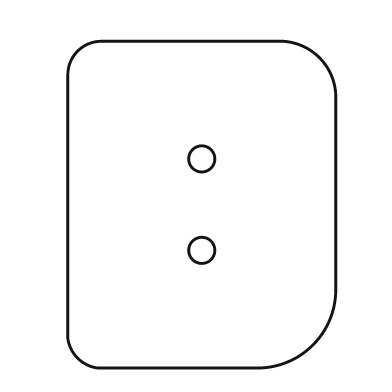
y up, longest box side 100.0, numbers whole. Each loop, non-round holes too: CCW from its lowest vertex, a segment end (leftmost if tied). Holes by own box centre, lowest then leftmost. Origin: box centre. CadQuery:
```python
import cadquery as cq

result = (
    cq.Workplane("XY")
    .moveTo(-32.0, -50.0)
    .lineTo(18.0, -50.0)
    .threePointArc((34.0, -43.0), (41.0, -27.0))
    .lineTo(41.0, 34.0)
    .threePointArc((36.0, 45.0), (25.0, 50.0))
    .lineTo(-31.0, 50.0)
    .threePointArc((-38.0, 47.0), (-41.0, 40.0))
    .lineTo(-41.0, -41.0)
    .threePointArc((-38.0, -47.0), (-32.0, -50.0))
    .close()
    .moveTo(0.0, -14.0)
    .circle(4.0)
    .moveTo(0.0, 14.0)
    .circle(4.0)
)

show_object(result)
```